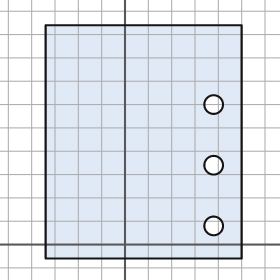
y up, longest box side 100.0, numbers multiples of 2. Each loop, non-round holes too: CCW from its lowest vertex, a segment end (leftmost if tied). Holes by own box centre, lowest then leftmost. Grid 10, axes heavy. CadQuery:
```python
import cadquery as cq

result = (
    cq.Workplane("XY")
    .moveTo(-34.0, -6.0)
    .lineTo(50.0, -6.0)
    .lineTo(50.0, 94.0)
    .lineTo(-34.0, 94.0)
    .close()
    .moveTo(38.0, 8.0)
    .circle(4.0)
    .moveTo(38.0, 34.0)
    .circle(4.0)
    .moveTo(38.0, 60.0)
    .circle(4.0)
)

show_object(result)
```